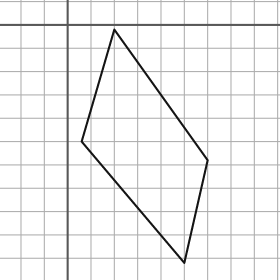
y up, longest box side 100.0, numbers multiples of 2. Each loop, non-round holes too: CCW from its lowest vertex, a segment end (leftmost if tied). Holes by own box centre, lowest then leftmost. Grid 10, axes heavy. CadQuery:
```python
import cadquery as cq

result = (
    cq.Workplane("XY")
    .moveTo(50.0, -102.0)
    .lineTo(60.0, -58.0)
    .lineTo(20.0, -2.0)
    .lineTo(6.0, -50.0)
    .close()
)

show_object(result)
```